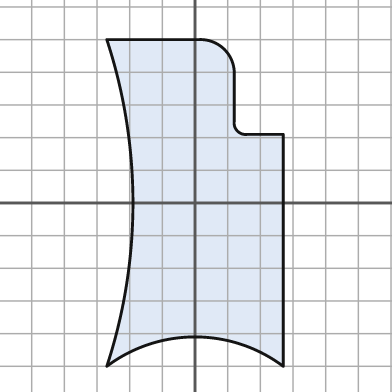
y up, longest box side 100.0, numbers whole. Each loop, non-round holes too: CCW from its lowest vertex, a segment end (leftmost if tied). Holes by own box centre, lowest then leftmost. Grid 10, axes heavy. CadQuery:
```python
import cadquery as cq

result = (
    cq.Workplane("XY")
    .moveTo(-27.0, -50.0)
    .threePointArc((0.0, -41.0), (27.0, -50.0))
    .lineTo(27.0, 21.0)
    .lineTo(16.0, 21.0)
    .threePointArc((13.0, 22.0), (12.0, 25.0))
    .lineTo(12.0, 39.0)
    .threePointArc((9.0, 47.0), (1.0, 50.0))
    .lineTo(-27.0, 50.0)
    .threePointArc((-19.0, 0.0), (-27.0, -50.0))
    .close()
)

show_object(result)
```